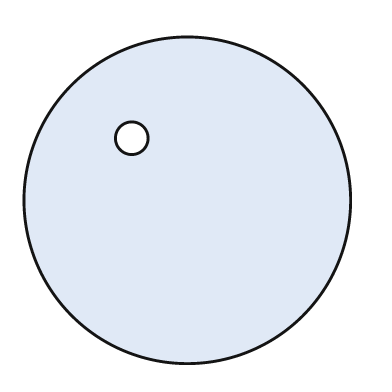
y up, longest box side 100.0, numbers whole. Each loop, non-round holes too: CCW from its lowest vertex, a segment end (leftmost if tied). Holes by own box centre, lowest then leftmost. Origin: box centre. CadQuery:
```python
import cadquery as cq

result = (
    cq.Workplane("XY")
    .moveTo(0.0, 0.0)
    .circle(50.0)
    .moveTo(-17.0, 19.0)
    .circle(5.0)
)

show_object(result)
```